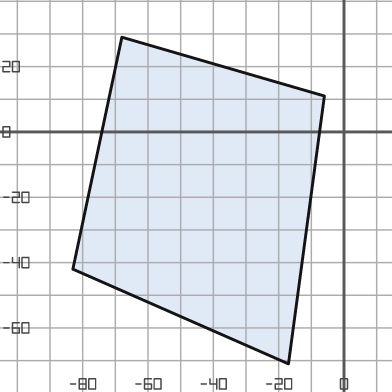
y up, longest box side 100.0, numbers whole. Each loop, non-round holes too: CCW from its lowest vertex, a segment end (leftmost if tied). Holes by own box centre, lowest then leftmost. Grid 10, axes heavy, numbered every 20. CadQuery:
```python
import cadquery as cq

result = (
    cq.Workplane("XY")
    .moveTo(-17.0, -71.0)
    .lineTo(-6.0, 11.0)
    .lineTo(-68.0, 29.0)
    .lineTo(-83.0, -42.0)
    .close()
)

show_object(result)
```